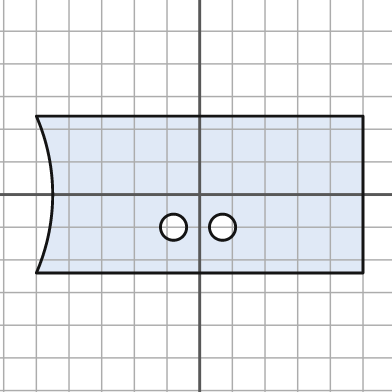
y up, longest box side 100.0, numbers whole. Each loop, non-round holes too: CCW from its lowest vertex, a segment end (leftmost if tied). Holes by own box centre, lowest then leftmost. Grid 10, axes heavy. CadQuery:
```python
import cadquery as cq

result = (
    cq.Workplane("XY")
    .moveTo(-50.0, -24.0)
    .lineTo(50.0, -24.0)
    .lineTo(50.0, 24.0)
    .lineTo(-50.0, 24.0)
    .threePointArc((-45.0, 0.0), (-50.0, -24.0))
    .close()
    .moveTo(-8.0, -10.0)
    .circle(4.0)
    .moveTo(7.0, -10.0)
    .circle(4.0)
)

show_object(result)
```